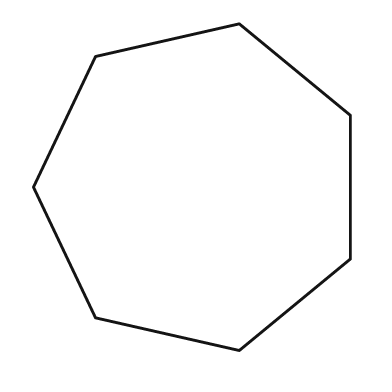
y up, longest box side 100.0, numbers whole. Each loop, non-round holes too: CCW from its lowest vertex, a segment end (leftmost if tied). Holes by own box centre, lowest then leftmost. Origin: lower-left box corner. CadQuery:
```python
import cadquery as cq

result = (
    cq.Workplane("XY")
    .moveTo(63.0, 0.0)
    .lineTo(97.0, 28.0)
    .lineTo(97.0, 72.0)
    .lineTo(63.0, 100.0)
    .lineTo(19.0, 90.0)
    .lineTo(0.0, 50.0)
    .lineTo(19.0, 10.0)
    .close()
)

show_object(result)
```